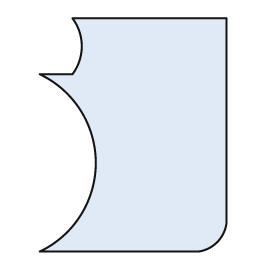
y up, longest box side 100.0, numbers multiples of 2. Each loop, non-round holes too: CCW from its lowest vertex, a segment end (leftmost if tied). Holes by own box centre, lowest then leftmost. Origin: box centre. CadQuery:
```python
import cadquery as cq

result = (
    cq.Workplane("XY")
    .moveTo(-40.0, -50.0)
    .lineTo(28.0, -50.0)
    .threePointArc((36.0, -46.0), (40.0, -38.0))
    .lineTo(40.0, 50.0)
    .lineTo(-26.0, 50.0)
    .threePointArc((-22.0, 38.0), (-26.0, 26.0))
    .lineTo(-40.0, 26.0)
    .threePointArc((-16.0, -12.0), (-40.0, -50.0))
    .close()
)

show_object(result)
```